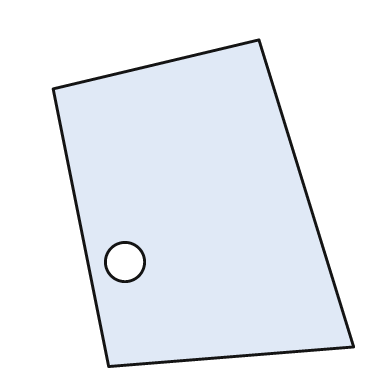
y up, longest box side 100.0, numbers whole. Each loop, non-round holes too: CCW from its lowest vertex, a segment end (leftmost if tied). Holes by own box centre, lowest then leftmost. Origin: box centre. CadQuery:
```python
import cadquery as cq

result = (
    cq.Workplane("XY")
    .moveTo(-29.0, -50.0)
    .lineTo(46.0, -44.0)
    .lineTo(17.0, 50.0)
    .lineTo(-46.0, 35.0)
    .close()
    .moveTo(-24.0, -18.0)
    .circle(6.0)
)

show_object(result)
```